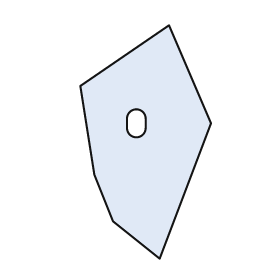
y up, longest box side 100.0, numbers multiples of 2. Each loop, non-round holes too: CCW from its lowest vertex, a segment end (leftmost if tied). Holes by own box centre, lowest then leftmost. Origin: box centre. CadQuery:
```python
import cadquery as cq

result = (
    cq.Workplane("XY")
    .moveTo(6.0, -50.0)
    .lineTo(28.0, 8.0)
    .lineTo(10.0, 50.0)
    .lineTo(-28.0, 24.0)
    .lineTo(-22.0, -14.0)
    .lineTo(-14.0, -34.0)
    .close()
    .moveTo(-8.0, 6.0)
    .threePointArc((-4.0, 2.0), (0.0, 6.0))
    .lineTo(0.0, 10.0)
    .threePointArc((-4.0, 14.0), (-8.0, 10.0))
    .close()
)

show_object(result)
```